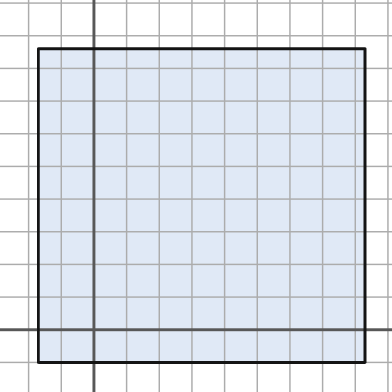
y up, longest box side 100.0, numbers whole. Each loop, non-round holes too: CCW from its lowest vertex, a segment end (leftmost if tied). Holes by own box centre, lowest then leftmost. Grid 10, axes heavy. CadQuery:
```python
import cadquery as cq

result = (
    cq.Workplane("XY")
    .moveTo(-17.0, -10.0)
    .lineTo(83.0, -10.0)
    .lineTo(83.0, 86.0)
    .lineTo(-17.0, 86.0)
    .close()
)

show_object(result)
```